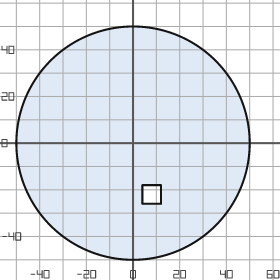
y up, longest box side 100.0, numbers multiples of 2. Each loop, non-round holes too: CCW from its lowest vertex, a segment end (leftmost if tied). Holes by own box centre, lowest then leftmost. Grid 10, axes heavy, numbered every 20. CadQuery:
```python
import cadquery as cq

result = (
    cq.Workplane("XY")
    .moveTo(0.0, 0.0)
    .circle(50.0)
    .moveTo(4.0, -26.0)
    .lineTo(12.0, -26.0)
    .lineTo(12.0, -18.0)
    .lineTo(4.0, -18.0)
    .close()
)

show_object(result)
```